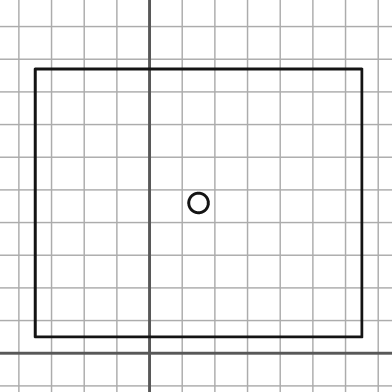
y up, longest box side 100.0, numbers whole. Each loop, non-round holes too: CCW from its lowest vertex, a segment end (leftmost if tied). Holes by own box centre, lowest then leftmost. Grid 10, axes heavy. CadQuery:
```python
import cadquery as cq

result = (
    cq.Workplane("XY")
    .moveTo(-35.0, 5.0)
    .lineTo(65.0, 5.0)
    .lineTo(65.0, 87.0)
    .lineTo(-35.0, 87.0)
    .close()
    .moveTo(15.0, 46.0)
    .circle(3.0)
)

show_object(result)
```